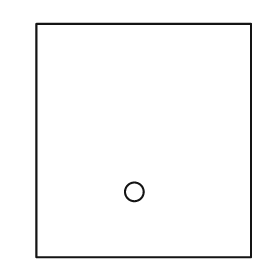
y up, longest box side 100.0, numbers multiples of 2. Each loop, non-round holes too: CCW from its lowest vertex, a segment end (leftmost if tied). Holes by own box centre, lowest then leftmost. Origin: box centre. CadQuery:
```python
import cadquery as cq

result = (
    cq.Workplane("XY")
    .moveTo(-46.0, -50.0)
    .lineTo(46.0, -50.0)
    .lineTo(46.0, 50.0)
    .lineTo(-46.0, 50.0)
    .close()
    .moveTo(-4.0, -22.0)
    .circle(4.0)
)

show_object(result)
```